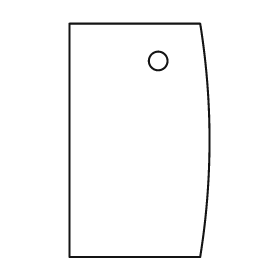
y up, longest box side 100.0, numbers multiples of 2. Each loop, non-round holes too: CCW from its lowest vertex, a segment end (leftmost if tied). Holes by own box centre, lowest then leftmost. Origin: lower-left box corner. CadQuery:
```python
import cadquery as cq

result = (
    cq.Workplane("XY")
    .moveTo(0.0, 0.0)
    .lineTo(56.0, 0.0)
    .threePointArc((60.0, 50.0), (56.0, 100.0))
    .lineTo(0.0, 100.0)
    .close()
    .moveTo(38.0, 84.0)
    .circle(4.0)
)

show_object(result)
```